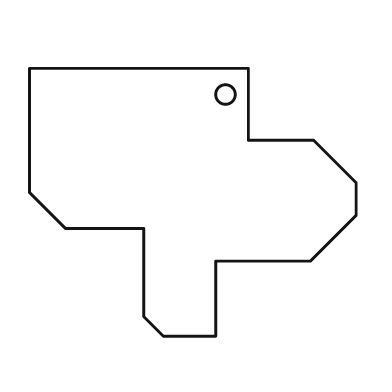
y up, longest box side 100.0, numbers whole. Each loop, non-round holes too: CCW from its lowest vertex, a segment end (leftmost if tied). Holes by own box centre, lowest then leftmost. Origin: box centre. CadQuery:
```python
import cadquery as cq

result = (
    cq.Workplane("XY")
    .moveTo(-9.0, -41.0)
    .lineTo(7.0, -41.0)
    .lineTo(7.0, -18.0)
    .lineTo(36.0, -18.0)
    .lineTo(50.0, -4.0)
    .lineTo(50.0, 6.0)
    .lineTo(37.0, 19.0)
    .lineTo(17.0, 19.0)
    .lineTo(17.0, 41.0)
    .lineTo(-50.0, 41.0)
    .lineTo(-50.0, 3.0)
    .lineTo(-39.0, -8.0)
    .lineTo(-15.0, -8.0)
    .lineTo(-15.0, -35.0)
    .close()
    .moveTo(10.0, 33.0)
    .circle(3.0)
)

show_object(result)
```